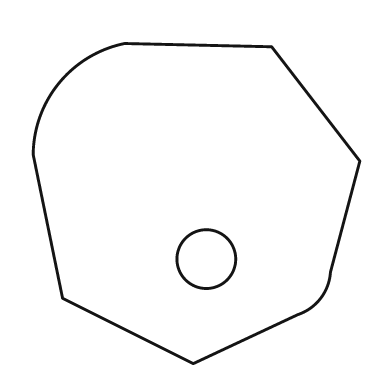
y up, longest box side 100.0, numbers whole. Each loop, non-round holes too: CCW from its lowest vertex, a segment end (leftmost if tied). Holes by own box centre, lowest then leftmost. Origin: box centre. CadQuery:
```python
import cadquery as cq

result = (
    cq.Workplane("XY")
    .moveTo(-1.0, -49.0)
    .lineTo(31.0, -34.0)
    .threePointArc((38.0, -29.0), (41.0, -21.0))
    .lineTo(50.0, 13.0)
    .lineTo(23.0, 48.0)
    .lineTo(-22.0, 49.0)
    .threePointArc((-42.0, 37.0), (-50.0, 15.0))
    .lineTo(-41.0, -29.0)
    .close()
    .moveTo(3.0, -17.0)
    .circle(9.0)
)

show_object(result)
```